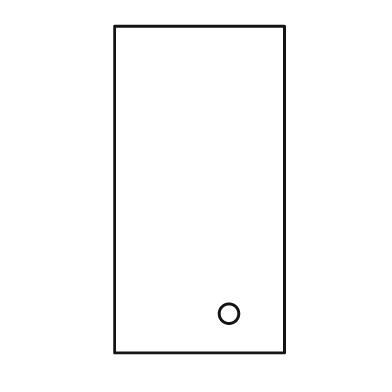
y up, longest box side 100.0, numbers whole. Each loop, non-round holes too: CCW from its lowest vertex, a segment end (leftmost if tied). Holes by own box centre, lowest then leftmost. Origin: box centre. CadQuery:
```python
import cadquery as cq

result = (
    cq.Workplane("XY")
    .moveTo(-26.0, -50.0)
    .lineTo(26.0, -50.0)
    .lineTo(26.0, 50.0)
    .lineTo(-26.0, 50.0)
    .close()
    .moveTo(9.0, -38.0)
    .circle(3.0)
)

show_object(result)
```